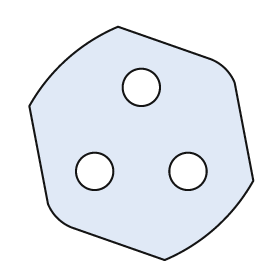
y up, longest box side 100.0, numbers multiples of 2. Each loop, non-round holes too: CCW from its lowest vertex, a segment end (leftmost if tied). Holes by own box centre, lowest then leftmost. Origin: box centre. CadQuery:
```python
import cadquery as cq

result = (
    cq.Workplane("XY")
    .moveTo(10.0, -50.0)
    .threePointArc((32.0, -36.0), (48.0, -16.0))
    .lineTo(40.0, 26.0)
    .threePointArc((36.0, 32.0), (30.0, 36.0))
    .lineTo(-10.0, 50.0)
    .threePointArc((-32.0, 36.0), (-48.0, 16.0))
    .lineTo(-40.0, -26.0)
    .threePointArc((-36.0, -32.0), (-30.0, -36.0))
    .close()
    .moveTo(-20.0, -12.0)
    .circle(8.0)
    .moveTo(20.0, -12.0)
    .circle(8.0)
    .moveTo(0.0, 24.0)
    .circle(8.0)
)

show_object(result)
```